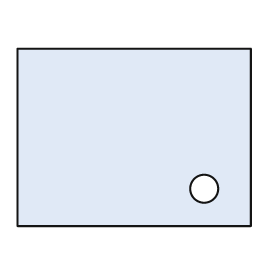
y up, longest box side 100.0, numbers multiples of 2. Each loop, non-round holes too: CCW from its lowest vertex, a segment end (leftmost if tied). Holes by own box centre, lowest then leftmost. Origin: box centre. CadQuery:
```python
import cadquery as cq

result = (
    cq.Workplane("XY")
    .moveTo(-50.0, -38.0)
    .lineTo(50.0, -38.0)
    .lineTo(50.0, 38.0)
    .lineTo(-50.0, 38.0)
    .close()
    .moveTo(30.0, -22.0)
    .circle(6.0)
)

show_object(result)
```